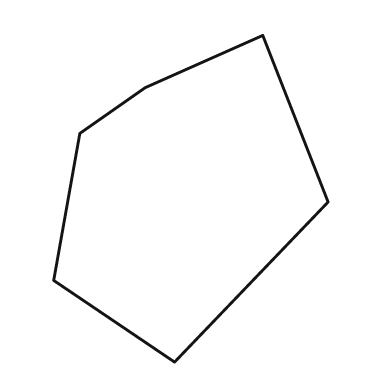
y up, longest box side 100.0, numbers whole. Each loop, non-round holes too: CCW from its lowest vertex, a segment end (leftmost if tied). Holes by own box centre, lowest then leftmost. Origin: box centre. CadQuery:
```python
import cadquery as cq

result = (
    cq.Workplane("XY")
    .moveTo(-5.0, -50.0)
    .lineTo(42.0, -1.0)
    .lineTo(22.0, 50.0)
    .lineTo(-14.0, 34.0)
    .lineTo(-34.0, 20.0)
    .lineTo(-42.0, -25.0)
    .close()
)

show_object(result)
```